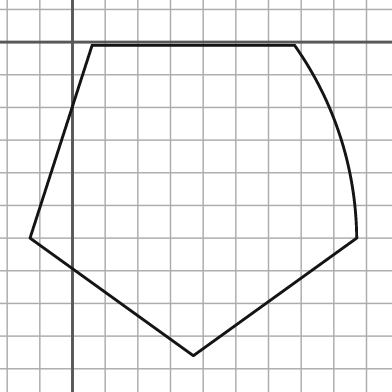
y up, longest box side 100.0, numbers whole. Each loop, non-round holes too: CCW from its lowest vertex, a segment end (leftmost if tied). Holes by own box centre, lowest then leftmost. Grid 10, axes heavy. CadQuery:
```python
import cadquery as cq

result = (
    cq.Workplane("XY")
    .moveTo(37.0, -96.0)
    .lineTo(87.0, -60.0)
    .threePointArc((82.0, -29.0), (68.0, -1.0))
    .lineTo(6.0, -1.0)
    .lineTo(-13.0, -60.0)
    .close()
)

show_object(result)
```